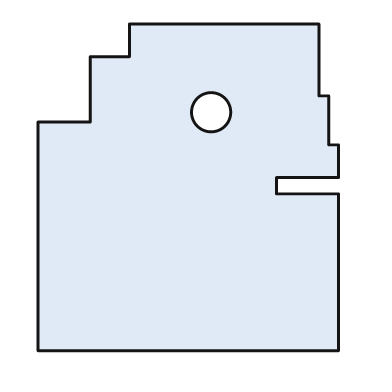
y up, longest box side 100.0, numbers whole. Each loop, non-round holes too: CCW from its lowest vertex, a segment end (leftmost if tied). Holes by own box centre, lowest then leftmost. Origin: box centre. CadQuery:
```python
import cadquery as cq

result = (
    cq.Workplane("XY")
    .moveTo(-46.0, -50.0)
    .lineTo(46.0, -50.0)
    .lineTo(46.0, -2.0)
    .lineTo(27.0, -2.0)
    .lineTo(27.0, 3.0)
    .lineTo(46.0, 3.0)
    .lineTo(46.0, 13.0)
    .lineTo(43.0, 13.0)
    .lineTo(43.0, 28.0)
    .lineTo(40.0, 28.0)
    .lineTo(40.0, 50.0)
    .lineTo(-18.0, 50.0)
    .lineTo(-18.0, 40.0)
    .lineTo(-30.0, 40.0)
    .lineTo(-30.0, 20.0)
    .lineTo(-46.0, 20.0)
    .close()
    .moveTo(7.0, 23.0)
    .circle(6.0)
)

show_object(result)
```